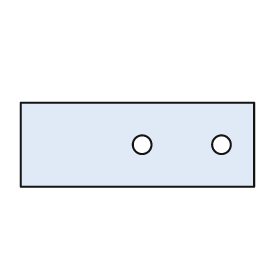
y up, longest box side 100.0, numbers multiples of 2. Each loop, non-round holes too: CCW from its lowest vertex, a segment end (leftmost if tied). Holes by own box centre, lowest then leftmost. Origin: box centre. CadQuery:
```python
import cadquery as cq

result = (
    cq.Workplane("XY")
    .moveTo(-50.0, -18.0)
    .lineTo(50.0, -18.0)
    .lineTo(50.0, 18.0)
    .lineTo(-50.0, 18.0)
    .close()
    .moveTo(2.0, 0.0)
    .circle(4.0)
    .moveTo(36.0, 0.0)
    .circle(4.0)
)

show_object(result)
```